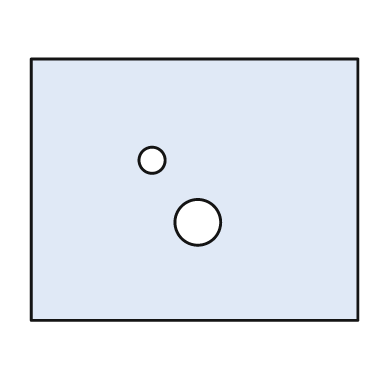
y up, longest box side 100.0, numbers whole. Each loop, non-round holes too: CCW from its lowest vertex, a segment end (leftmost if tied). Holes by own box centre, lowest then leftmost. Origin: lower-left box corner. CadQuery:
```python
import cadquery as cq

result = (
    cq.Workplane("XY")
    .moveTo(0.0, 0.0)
    .lineTo(100.0, 0.0)
    .lineTo(100.0, 80.0)
    .lineTo(0.0, 80.0)
    .close()
    .moveTo(51.0, 30.0)
    .circle(7.0)
    .moveTo(37.0, 49.0)
    .circle(4.0)
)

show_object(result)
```